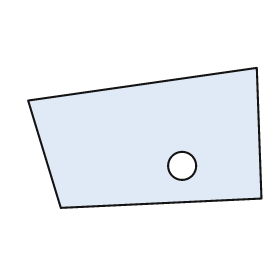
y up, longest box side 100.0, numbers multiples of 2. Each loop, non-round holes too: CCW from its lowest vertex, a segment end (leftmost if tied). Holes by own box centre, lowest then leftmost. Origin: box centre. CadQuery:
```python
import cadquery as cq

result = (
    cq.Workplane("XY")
    .moveTo(-36.0, -30.0)
    .lineTo(50.0, -26.0)
    .lineTo(48.0, 30.0)
    .lineTo(-50.0, 16.0)
    .close()
    .moveTo(16.0, -12.0)
    .circle(6.0)
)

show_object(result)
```